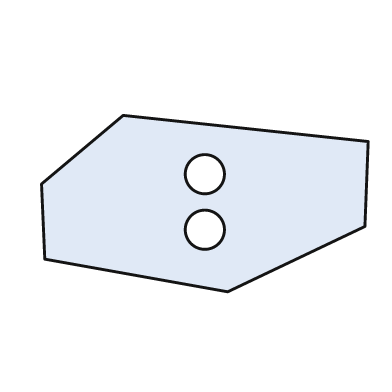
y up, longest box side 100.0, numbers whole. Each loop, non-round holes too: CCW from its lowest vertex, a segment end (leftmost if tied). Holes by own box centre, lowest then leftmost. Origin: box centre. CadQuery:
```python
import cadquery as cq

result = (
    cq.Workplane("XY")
    .moveTo(7.0, -27.0)
    .lineTo(49.0, -7.0)
    .lineTo(50.0, 19.0)
    .lineTo(-25.0, 27.0)
    .lineTo(-50.0, 6.0)
    .lineTo(-49.0, -17.0)
    .close()
    .moveTo(0.0, -8.0)
    .circle(6.0)
    .moveTo(0.0, 9.0)
    .circle(6.0)
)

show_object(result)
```